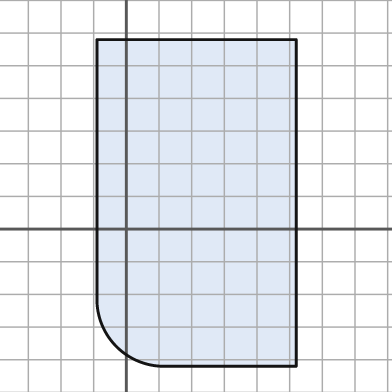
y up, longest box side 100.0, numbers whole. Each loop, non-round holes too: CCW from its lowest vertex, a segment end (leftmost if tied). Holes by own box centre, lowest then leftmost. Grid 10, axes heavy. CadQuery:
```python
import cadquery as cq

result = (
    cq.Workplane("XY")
    .moveTo(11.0, -42.0)
    .lineTo(52.0, -42.0)
    .lineTo(52.0, 58.0)
    .lineTo(-9.0, 58.0)
    .lineTo(-9.0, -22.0)
    .threePointArc((-3.0, -36.0), (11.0, -42.0))
    .close()
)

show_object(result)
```